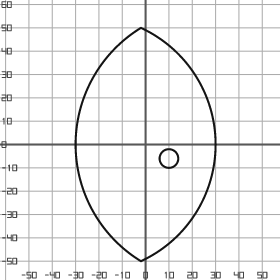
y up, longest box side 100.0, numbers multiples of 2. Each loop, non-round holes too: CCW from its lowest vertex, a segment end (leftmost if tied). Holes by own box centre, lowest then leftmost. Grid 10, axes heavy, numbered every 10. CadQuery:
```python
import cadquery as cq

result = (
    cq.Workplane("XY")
    .moveTo(-2.0, -50.0)
    .threePointArc((30.0, 0.0), (-2.0, 50.0))
    .threePointArc((-30.0, 0.0), (-2.0, -50.0))
    .close()
    .moveTo(10.0, -6.0)
    .circle(4.0)
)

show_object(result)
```